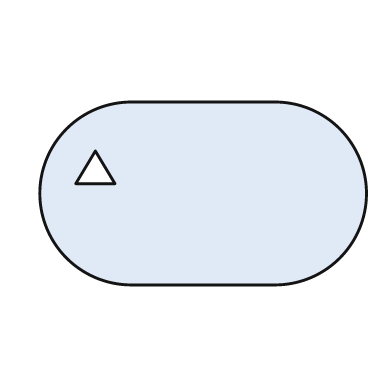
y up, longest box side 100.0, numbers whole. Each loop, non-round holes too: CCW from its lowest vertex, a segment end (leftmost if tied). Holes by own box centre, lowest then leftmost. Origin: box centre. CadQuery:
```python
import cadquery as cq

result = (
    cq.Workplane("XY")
    .moveTo(-22.0, -28.0)
    .lineTo(22.0, -28.0)
    .threePointArc((50.0, 0.0), (22.0, 28.0))
    .lineTo(-22.0, 28.0)
    .threePointArc((-50.0, 0.0), (-22.0, -28.0))
    .close()
    .moveTo(-39.0, 3.0)
    .lineTo(-27.0, 3.0)
    .lineTo(-33.0, 13.0)
    .close()
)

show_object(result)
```